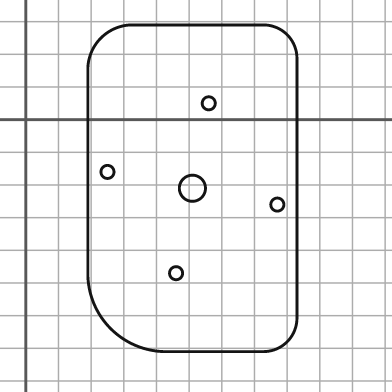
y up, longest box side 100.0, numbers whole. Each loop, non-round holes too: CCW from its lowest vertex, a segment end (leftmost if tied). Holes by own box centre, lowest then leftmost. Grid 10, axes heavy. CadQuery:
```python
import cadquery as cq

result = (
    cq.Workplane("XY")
    .moveTo(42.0, -71.0)
    .lineTo(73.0, -71.0)
    .threePointArc((80.0, -68.0), (83.0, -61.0))
    .lineTo(83.0, 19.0)
    .threePointArc((80.0, 26.0), (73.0, 29.0))
    .lineTo(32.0, 29.0)
    .threePointArc((23.0, 25.0), (19.0, 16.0))
    .lineTo(19.0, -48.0)
    .threePointArc((26.0, -64.0), (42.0, -71.0))
    .close()
    .moveTo(46.0, -47.0)
    .circle(2.0)
    .moveTo(77.0, -26.0)
    .circle(2.0)
    .moveTo(51.0, -21.0)
    .circle(4.0)
    .moveTo(25.0, -16.0)
    .circle(2.0)
    .moveTo(56.0, 5.0)
    .circle(2.0)
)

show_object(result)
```